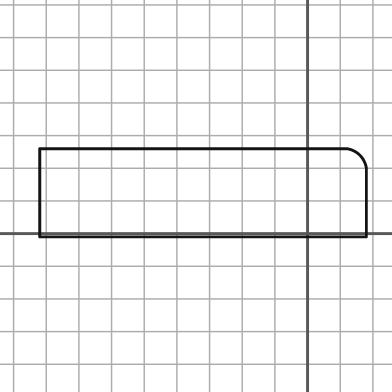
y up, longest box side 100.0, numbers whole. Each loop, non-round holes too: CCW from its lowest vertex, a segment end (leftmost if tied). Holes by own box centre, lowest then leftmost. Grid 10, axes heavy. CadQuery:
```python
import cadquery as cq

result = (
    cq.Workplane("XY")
    .moveTo(-82.0, -1.0)
    .lineTo(18.0, -1.0)
    .lineTo(18.0, 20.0)
    .threePointArc((16.0, 24.0), (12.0, 26.0))
    .lineTo(-82.0, 26.0)
    .close()
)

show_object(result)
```